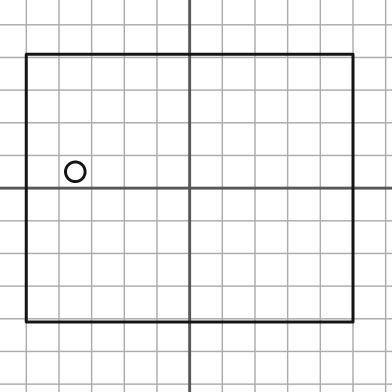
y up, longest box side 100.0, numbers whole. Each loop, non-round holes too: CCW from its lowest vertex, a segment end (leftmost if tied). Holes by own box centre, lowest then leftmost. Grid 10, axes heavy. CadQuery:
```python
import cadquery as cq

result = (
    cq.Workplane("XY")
    .moveTo(-50.0, -41.0)
    .lineTo(50.0, -41.0)
    .lineTo(50.0, 41.0)
    .lineTo(-50.0, 41.0)
    .close()
    .moveTo(-35.0, 5.0)
    .circle(3.0)
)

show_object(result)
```